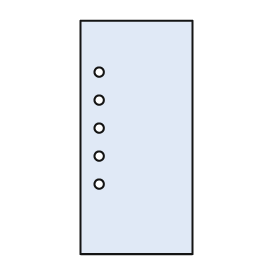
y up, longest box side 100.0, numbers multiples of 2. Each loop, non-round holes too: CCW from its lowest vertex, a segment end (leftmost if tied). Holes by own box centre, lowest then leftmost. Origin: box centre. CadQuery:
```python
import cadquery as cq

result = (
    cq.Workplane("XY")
    .moveTo(-24.0, -50.0)
    .lineTo(24.0, -50.0)
    .lineTo(24.0, 50.0)
    .lineTo(-24.0, 50.0)
    .close()
    .moveTo(-16.0, -20.0)
    .circle(2.0)
    .moveTo(-16.0, -8.0)
    .circle(2.0)
    .moveTo(-16.0, 4.0)
    .circle(2.0)
    .moveTo(-16.0, 16.0)
    .circle(2.0)
    .moveTo(-16.0, 28.0)
    .circle(2.0)
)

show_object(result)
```